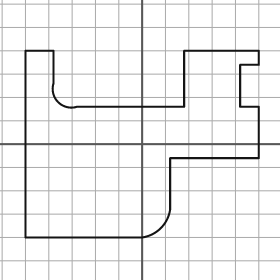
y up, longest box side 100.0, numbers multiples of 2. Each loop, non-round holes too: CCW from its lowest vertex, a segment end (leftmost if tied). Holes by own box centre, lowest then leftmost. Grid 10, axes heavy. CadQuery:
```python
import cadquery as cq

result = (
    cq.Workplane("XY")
    .moveTo(-50.0, -40.0)
    .lineTo(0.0, -40.0)
    .threePointArc((8.0, -36.0), (12.0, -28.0))
    .lineTo(12.0, -6.0)
    .lineTo(50.0, -6.0)
    .lineTo(50.0, 16.0)
    .lineTo(42.0, 16.0)
    .lineTo(42.0, 34.0)
    .lineTo(50.0, 34.0)
    .lineTo(50.0, 40.0)
    .lineTo(18.0, 40.0)
    .lineTo(18.0, 16.0)
    .lineTo(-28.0, 16.0)
    .threePointArc((-36.0, 18.0), (-38.0, 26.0))
    .lineTo(-38.0, 40.0)
    .lineTo(-50.0, 40.0)
    .close()
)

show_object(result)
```